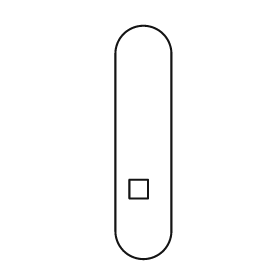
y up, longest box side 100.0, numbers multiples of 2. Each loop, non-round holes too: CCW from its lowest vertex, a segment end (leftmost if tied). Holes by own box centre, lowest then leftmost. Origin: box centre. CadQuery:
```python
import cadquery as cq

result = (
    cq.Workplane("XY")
    .moveTo(-12.0, -38.0)
    .threePointArc((0.0, -50.0), (12.0, -38.0))
    .lineTo(12.0, 38.0)
    .threePointArc((0.0, 50.0), (-12.0, 38.0))
    .close()
    .moveTo(-6.0, -24.0)
    .lineTo(2.0, -24.0)
    .lineTo(2.0, -16.0)
    .lineTo(-6.0, -16.0)
    .close()
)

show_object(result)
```